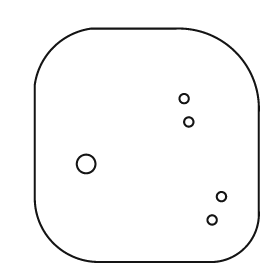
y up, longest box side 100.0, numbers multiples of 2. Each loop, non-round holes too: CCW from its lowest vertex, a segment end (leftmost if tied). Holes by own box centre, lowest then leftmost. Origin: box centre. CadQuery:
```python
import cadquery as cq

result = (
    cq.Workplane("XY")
    .moveTo(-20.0, -50.0)
    .lineTo(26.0, -50.0)
    .threePointArc((42.0, -44.0), (48.0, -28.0))
    .lineTo(48.0, 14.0)
    .threePointArc((38.0, 40.0), (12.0, 50.0))
    .lineTo(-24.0, 50.0)
    .threePointArc((-40.0, 42.0), (-48.0, 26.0))
    .lineTo(-48.0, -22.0)
    .threePointArc((-40.0, -42.0), (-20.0, -50.0))
    .close()
    .moveTo(28.0, -32.0)
    .circle(2.0)
    .moveTo(32.0, -22.0)
    .circle(2.0)
    .moveTo(-26.0, -8.0)
    .circle(4.0)
    .moveTo(18.0, 10.0)
    .circle(2.0)
    .moveTo(16.0, 20.0)
    .circle(2.0)
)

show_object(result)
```